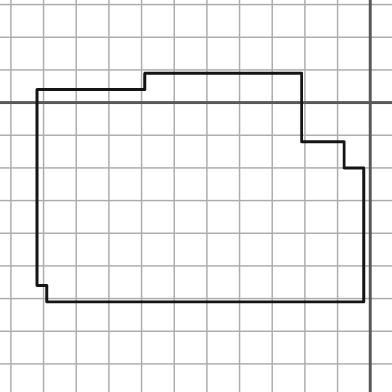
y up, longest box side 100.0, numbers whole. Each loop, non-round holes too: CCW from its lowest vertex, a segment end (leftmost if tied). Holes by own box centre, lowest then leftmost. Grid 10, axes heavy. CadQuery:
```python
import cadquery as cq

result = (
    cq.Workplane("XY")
    .moveTo(-99.0, -61.0)
    .lineTo(-2.0, -61.0)
    .lineTo(-2.0, -20.0)
    .lineTo(-8.0, -20.0)
    .lineTo(-8.0, -12.0)
    .lineTo(-21.0, -12.0)
    .lineTo(-21.0, 9.0)
    .lineTo(-69.0, 9.0)
    .lineTo(-69.0, 4.0)
    .lineTo(-102.0, 4.0)
    .lineTo(-102.0, -56.0)
    .lineTo(-99.0, -56.0)
    .close()
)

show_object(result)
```